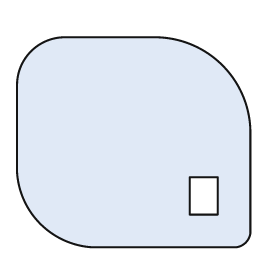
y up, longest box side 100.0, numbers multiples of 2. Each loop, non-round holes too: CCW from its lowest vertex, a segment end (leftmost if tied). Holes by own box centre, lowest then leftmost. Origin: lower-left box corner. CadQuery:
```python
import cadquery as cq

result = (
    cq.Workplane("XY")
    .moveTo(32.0, 0.0)
    .lineTo(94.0, 0.0)
    .threePointArc((98.0, 2.0), (100.0, 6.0))
    .lineTo(100.0, 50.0)
    .threePointArc((88.0, 78.0), (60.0, 90.0))
    .lineTo(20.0, 90.0)
    .threePointArc((6.0, 84.0), (0.0, 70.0))
    .lineTo(0.0, 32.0)
    .threePointArc((10.0, 10.0), (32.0, 0.0))
    .close()
    .moveTo(74.0, 14.0)
    .lineTo(86.0, 14.0)
    .lineTo(86.0, 30.0)
    .lineTo(74.0, 30.0)
    .close()
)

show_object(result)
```